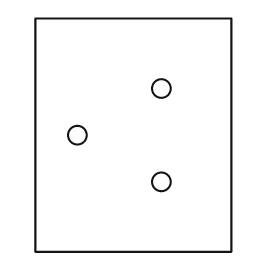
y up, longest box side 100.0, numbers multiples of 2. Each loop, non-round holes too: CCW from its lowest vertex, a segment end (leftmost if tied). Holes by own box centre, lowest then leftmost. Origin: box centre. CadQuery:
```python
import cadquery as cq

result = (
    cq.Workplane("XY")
    .moveTo(-42.0, -50.0)
    .lineTo(42.0, -50.0)
    .lineTo(42.0, 50.0)
    .lineTo(-42.0, 50.0)
    .close()
    .moveTo(12.0, -20.0)
    .circle(4.0)
    .moveTo(-24.0, 0.0)
    .circle(4.0)
    .moveTo(12.0, 20.0)
    .circle(4.0)
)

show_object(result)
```